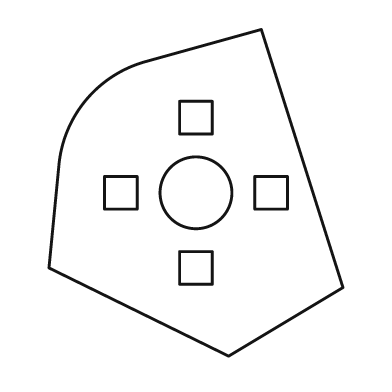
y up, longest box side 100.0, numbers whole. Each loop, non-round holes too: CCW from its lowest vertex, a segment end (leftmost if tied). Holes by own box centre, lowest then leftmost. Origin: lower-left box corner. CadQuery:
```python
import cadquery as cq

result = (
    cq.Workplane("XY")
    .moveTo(55.0, 0.0)
    .lineTo(90.0, 21.0)
    .lineTo(65.0, 100.0)
    .lineTo(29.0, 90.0)
    .threePointArc((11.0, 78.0), (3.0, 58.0))
    .lineTo(0.0, 27.0)
    .close()
    .moveTo(40.0, 22.0)
    .lineTo(50.0, 22.0)
    .lineTo(50.0, 32.0)
    .lineTo(40.0, 32.0)
    .close()
    .moveTo(17.0, 45.0)
    .lineTo(27.0, 45.0)
    .lineTo(27.0, 55.0)
    .lineTo(17.0, 55.0)
    .close()
    .moveTo(45.0, 50.0)
    .circle(11.0)
    .moveTo(63.0, 45.0)
    .lineTo(73.0, 45.0)
    .lineTo(73.0, 55.0)
    .lineTo(63.0, 55.0)
    .close()
    .moveTo(40.0, 68.0)
    .lineTo(50.0, 68.0)
    .lineTo(50.0, 78.0)
    .lineTo(40.0, 78.0)
    .close()
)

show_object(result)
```